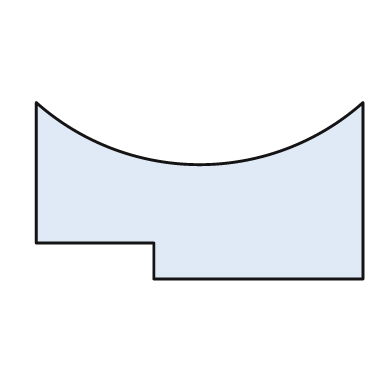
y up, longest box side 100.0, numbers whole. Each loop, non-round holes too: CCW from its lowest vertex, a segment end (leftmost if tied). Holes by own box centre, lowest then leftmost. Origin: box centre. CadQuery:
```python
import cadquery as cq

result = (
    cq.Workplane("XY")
    .moveTo(-14.0, -27.0)
    .lineTo(50.0, -27.0)
    .lineTo(50.0, 27.0)
    .threePointArc((0.0, 8.0), (-50.0, 27.0))
    .lineTo(-50.0, -16.0)
    .lineTo(-14.0, -16.0)
    .close()
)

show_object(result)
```